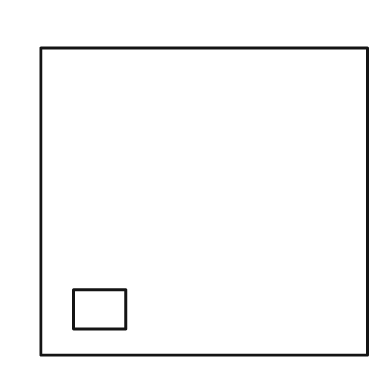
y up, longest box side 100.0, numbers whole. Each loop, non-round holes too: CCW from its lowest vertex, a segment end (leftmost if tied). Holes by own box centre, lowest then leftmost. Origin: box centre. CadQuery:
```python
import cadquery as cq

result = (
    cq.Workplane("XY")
    .moveTo(-50.0, -47.0)
    .lineTo(50.0, -47.0)
    .lineTo(50.0, 47.0)
    .lineTo(-50.0, 47.0)
    .close()
    .moveTo(-40.0, -39.0)
    .lineTo(-24.0, -39.0)
    .lineTo(-24.0, -27.0)
    .lineTo(-40.0, -27.0)
    .close()
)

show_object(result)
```